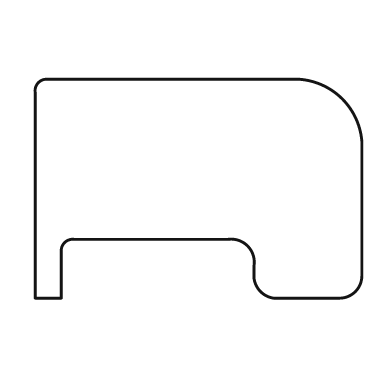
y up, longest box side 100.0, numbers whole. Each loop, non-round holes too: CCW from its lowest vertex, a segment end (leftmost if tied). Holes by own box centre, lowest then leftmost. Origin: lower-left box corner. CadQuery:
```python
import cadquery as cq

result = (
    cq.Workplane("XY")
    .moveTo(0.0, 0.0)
    .lineTo(8.0, 0.0)
    .lineTo(8.0, 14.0)
    .threePointArc((9.0, 17.0), (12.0, 18.0))
    .lineTo(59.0, 18.0)
    .threePointArc((65.0, 16.0), (67.0, 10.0))
    .lineTo(67.0, 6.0)
    .threePointArc((69.0, 2.0), (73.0, 0.0))
    .lineTo(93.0, 0.0)
    .threePointArc((98.0, 2.0), (100.0, 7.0))
    .lineTo(100.0, 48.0)
    .threePointArc((94.0, 61.0), (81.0, 67.0))
    .lineTo(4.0, 67.0)
    .threePointArc((1.0, 66.0), (0.0, 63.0))
    .close()
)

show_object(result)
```